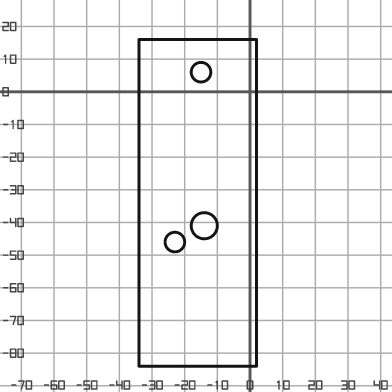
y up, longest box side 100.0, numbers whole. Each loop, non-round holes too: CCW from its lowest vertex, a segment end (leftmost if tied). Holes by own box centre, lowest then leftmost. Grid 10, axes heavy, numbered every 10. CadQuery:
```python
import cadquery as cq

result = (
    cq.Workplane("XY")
    .moveTo(-34.0, -84.0)
    .lineTo(2.0, -84.0)
    .lineTo(2.0, 16.0)
    .lineTo(-34.0, 16.0)
    .close()
    .moveTo(-23.0, -46.0)
    .circle(3.0)
    .moveTo(-14.0, -41.0)
    .circle(4.0)
    .moveTo(-15.0, 6.0)
    .circle(3.0)
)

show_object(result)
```